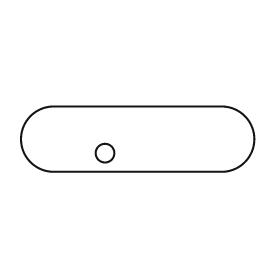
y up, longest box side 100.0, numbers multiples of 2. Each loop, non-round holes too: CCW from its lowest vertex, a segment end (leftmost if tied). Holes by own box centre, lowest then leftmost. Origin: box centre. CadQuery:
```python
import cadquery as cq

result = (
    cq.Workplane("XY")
    .moveTo(-36.0, -14.0)
    .lineTo(36.0, -14.0)
    .threePointArc((50.0, 0.0), (36.0, 14.0))
    .lineTo(-36.0, 14.0)
    .threePointArc((-50.0, 0.0), (-36.0, -14.0))
    .close()
    .moveTo(-14.0, -6.0)
    .circle(4.0)
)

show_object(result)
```